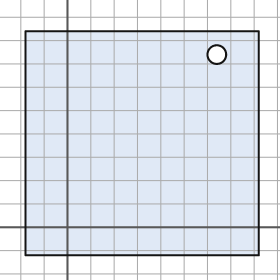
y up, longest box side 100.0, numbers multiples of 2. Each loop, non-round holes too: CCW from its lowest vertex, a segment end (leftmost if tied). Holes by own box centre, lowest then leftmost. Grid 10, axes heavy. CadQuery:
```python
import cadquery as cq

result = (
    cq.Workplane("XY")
    .moveTo(-18.0, -12.0)
    .lineTo(82.0, -12.0)
    .lineTo(82.0, 84.0)
    .lineTo(-18.0, 84.0)
    .close()
    .moveTo(64.0, 74.0)
    .circle(4.0)
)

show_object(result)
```